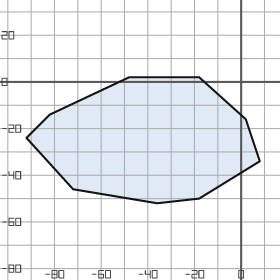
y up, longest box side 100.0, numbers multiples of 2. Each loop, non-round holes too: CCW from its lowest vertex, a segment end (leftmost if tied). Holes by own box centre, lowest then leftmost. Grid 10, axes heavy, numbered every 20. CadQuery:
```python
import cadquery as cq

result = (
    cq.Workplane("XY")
    .moveTo(-36.0, -52.0)
    .lineTo(-18.0, -50.0)
    .lineTo(8.0, -34.0)
    .lineTo(2.0, -16.0)
    .lineTo(-18.0, 2.0)
    .lineTo(-48.0, 2.0)
    .lineTo(-82.0, -14.0)
    .lineTo(-92.0, -24.0)
    .lineTo(-72.0, -46.0)
    .close()
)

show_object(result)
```